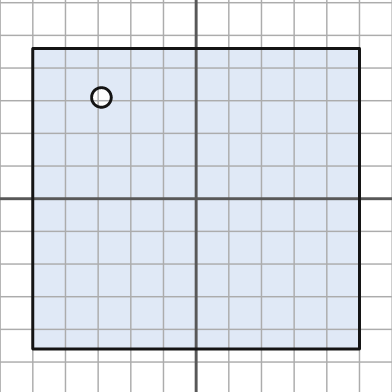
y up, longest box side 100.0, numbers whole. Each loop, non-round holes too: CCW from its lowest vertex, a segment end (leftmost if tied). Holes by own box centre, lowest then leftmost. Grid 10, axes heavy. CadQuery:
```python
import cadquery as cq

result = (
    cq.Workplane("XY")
    .moveTo(-50.0, -46.0)
    .lineTo(50.0, -46.0)
    .lineTo(50.0, 46.0)
    .lineTo(-50.0, 46.0)
    .close()
    .moveTo(-29.0, 31.0)
    .circle(3.0)
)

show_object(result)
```